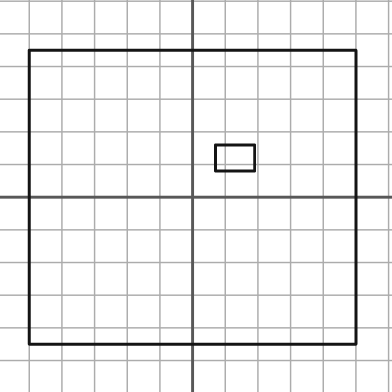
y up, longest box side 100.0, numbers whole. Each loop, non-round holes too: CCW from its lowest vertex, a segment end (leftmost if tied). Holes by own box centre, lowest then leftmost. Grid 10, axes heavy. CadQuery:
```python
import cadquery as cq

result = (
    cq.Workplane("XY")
    .moveTo(-50.0, -45.0)
    .lineTo(50.0, -45.0)
    .lineTo(50.0, 45.0)
    .lineTo(-50.0, 45.0)
    .close()
    .moveTo(7.0, 8.0)
    .lineTo(19.0, 8.0)
    .lineTo(19.0, 16.0)
    .lineTo(7.0, 16.0)
    .close()
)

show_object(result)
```